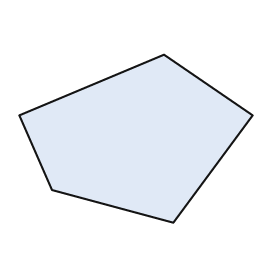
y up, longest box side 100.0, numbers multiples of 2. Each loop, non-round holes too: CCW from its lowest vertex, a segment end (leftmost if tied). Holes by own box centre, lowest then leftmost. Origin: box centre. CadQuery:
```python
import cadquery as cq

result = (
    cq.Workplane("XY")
    .moveTo(16.0, -36.0)
    .lineTo(50.0, 10.0)
    .lineTo(12.0, 36.0)
    .lineTo(-50.0, 10.0)
    .lineTo(-36.0, -22.0)
    .close()
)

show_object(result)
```